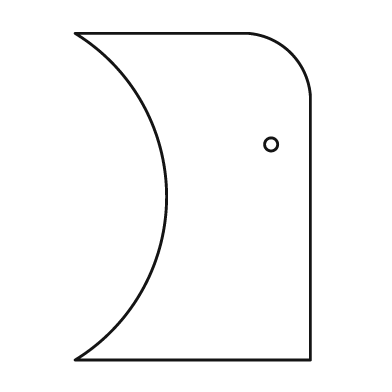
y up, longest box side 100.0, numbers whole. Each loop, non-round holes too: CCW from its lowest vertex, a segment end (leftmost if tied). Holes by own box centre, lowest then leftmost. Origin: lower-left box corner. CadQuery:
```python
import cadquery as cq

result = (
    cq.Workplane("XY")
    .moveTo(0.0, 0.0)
    .lineTo(72.0, 0.0)
    .lineTo(72.0, 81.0)
    .threePointArc((66.0, 94.0), (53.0, 100.0))
    .lineTo(0.0, 100.0)
    .threePointArc((28.0, 50.0), (0.0, 0.0))
    .close()
    .moveTo(60.0, 66.0)
    .circle(2.0)
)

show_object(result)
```